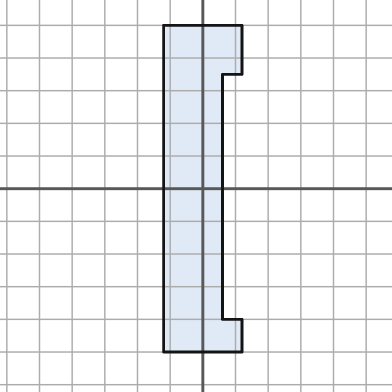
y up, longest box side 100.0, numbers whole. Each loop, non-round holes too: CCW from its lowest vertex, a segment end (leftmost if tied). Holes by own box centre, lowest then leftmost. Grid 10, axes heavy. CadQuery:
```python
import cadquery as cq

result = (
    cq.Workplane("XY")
    .moveTo(-12.0, -50.0)
    .lineTo(12.0, -50.0)
    .lineTo(12.0, -40.0)
    .lineTo(6.0, -40.0)
    .lineTo(6.0, 35.0)
    .lineTo(12.0, 35.0)
    .lineTo(12.0, 50.0)
    .lineTo(-12.0, 50.0)
    .close()
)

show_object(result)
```